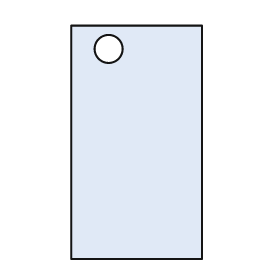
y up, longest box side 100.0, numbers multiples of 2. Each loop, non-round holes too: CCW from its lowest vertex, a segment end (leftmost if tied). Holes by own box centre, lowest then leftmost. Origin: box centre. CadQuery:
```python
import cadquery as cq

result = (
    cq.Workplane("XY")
    .moveTo(-28.0, -50.0)
    .lineTo(28.0, -50.0)
    .lineTo(28.0, 50.0)
    .lineTo(-28.0, 50.0)
    .close()
    .moveTo(-12.0, 40.0)
    .circle(6.0)
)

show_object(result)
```